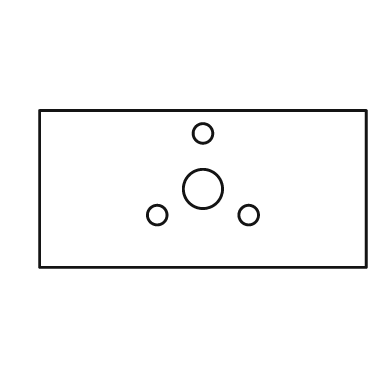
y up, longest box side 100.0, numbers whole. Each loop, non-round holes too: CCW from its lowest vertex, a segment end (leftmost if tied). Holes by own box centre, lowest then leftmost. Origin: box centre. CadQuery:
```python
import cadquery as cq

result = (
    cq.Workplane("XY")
    .moveTo(-50.0, -24.0)
    .lineTo(50.0, -24.0)
    .lineTo(50.0, 24.0)
    .lineTo(-50.0, 24.0)
    .close()
    .moveTo(-14.0, -8.0)
    .circle(3.0)
    .moveTo(14.0, -8.0)
    .circle(3.0)
    .moveTo(0.0, 0.0)
    .circle(6.0)
    .moveTo(0.0, 17.0)
    .circle(3.0)
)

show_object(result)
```